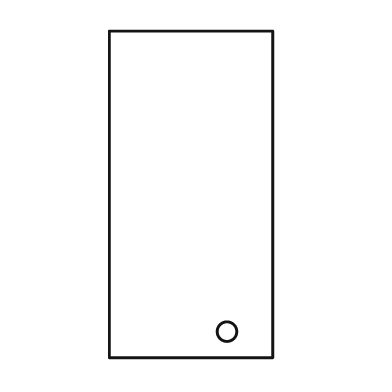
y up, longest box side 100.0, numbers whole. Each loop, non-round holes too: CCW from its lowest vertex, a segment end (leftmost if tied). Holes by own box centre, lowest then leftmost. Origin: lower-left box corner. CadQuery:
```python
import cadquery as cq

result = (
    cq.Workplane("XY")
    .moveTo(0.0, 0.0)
    .lineTo(50.0, 0.0)
    .lineTo(50.0, 100.0)
    .lineTo(0.0, 100.0)
    .close()
    .moveTo(36.0, 8.0)
    .circle(3.0)
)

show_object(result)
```